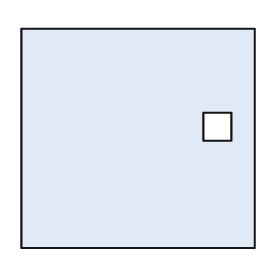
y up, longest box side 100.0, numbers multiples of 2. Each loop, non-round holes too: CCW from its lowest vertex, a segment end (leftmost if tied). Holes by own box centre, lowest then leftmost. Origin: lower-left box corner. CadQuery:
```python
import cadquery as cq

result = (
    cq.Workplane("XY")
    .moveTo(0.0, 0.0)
    .lineTo(100.0, 0.0)
    .lineTo(100.0, 94.0)
    .lineTo(0.0, 94.0)
    .close()
    .moveTo(78.0, 46.0)
    .lineTo(90.0, 46.0)
    .lineTo(90.0, 58.0)
    .lineTo(78.0, 58.0)
    .close()
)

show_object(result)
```